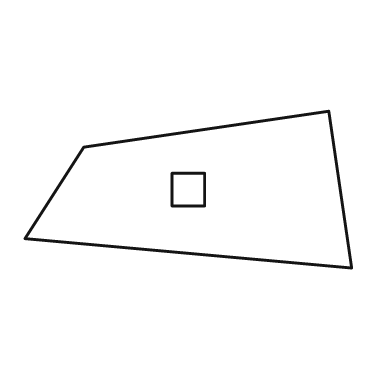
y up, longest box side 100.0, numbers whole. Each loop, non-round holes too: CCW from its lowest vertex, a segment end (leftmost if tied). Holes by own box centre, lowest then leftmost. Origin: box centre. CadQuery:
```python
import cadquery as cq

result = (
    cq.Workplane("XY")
    .moveTo(50.0, -24.0)
    .lineTo(43.0, 24.0)
    .lineTo(-32.0, 13.0)
    .lineTo(-50.0, -15.0)
    .close()
    .moveTo(-5.0, -5.0)
    .lineTo(5.0, -5.0)
    .lineTo(5.0, 5.0)
    .lineTo(-5.0, 5.0)
    .close()
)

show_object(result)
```